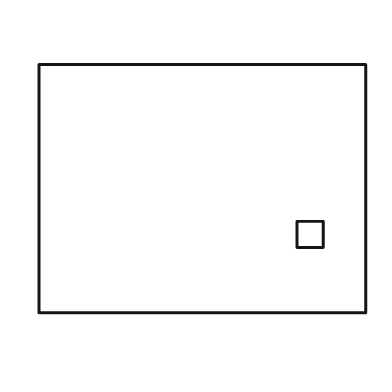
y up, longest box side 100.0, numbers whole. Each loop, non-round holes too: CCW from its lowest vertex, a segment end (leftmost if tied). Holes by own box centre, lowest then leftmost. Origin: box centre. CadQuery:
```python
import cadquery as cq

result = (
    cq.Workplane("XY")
    .moveTo(-50.0, -38.0)
    .lineTo(50.0, -38.0)
    .lineTo(50.0, 38.0)
    .lineTo(-50.0, 38.0)
    .close()
    .moveTo(29.0, -18.0)
    .lineTo(37.0, -18.0)
    .lineTo(37.0, -10.0)
    .lineTo(29.0, -10.0)
    .close()
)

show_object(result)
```